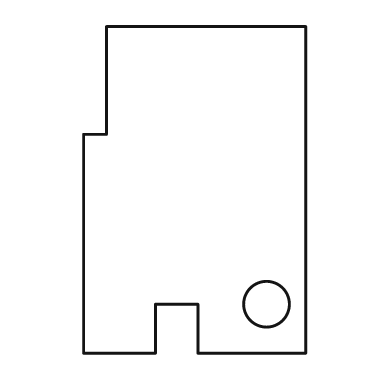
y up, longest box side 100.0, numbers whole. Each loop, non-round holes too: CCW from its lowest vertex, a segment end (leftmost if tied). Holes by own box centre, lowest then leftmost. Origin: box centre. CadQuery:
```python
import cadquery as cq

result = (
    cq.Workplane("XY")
    .moveTo(-34.0, -50.0)
    .lineTo(-12.0, -50.0)
    .lineTo(-12.0, -35.0)
    .lineTo(1.0, -35.0)
    .lineTo(1.0, -50.0)
    .lineTo(34.0, -50.0)
    .lineTo(34.0, 50.0)
    .lineTo(-27.0, 50.0)
    .lineTo(-27.0, 17.0)
    .lineTo(-34.0, 17.0)
    .close()
    .moveTo(22.0, -35.0)
    .circle(7.0)
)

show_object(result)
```